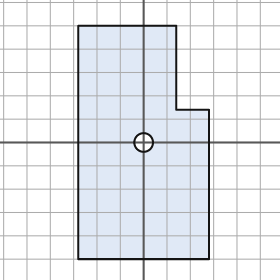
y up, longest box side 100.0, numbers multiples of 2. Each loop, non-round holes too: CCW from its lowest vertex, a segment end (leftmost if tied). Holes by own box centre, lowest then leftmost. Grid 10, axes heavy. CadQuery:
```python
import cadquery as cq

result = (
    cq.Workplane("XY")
    .moveTo(-28.0, -50.0)
    .lineTo(28.0, -50.0)
    .lineTo(28.0, 14.0)
    .lineTo(14.0, 14.0)
    .lineTo(14.0, 50.0)
    .lineTo(-28.0, 50.0)
    .close()
    .moveTo(0.0, 0.0)
    .circle(4.0)
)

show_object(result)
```